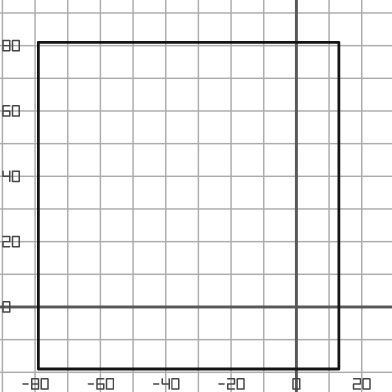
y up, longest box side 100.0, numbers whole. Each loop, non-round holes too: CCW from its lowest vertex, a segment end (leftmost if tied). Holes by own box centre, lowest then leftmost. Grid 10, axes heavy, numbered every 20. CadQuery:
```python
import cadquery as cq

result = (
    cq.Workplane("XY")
    .moveTo(-79.0, -19.0)
    .lineTo(13.0, -19.0)
    .lineTo(13.0, 81.0)
    .lineTo(-79.0, 81.0)
    .close()
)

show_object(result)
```